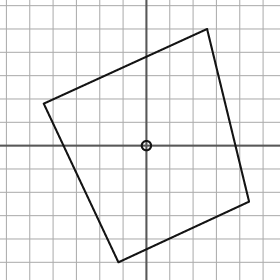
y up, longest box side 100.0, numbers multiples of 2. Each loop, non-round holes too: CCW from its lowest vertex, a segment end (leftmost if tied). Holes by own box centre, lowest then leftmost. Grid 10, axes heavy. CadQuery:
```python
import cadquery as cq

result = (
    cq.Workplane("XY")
    .moveTo(-12.0, -50.0)
    .lineTo(44.0, -24.0)
    .lineTo(26.0, 50.0)
    .lineTo(-44.0, 18.0)
    .close()
    .moveTo(0.0, 0.0)
    .circle(2.0)
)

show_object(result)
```